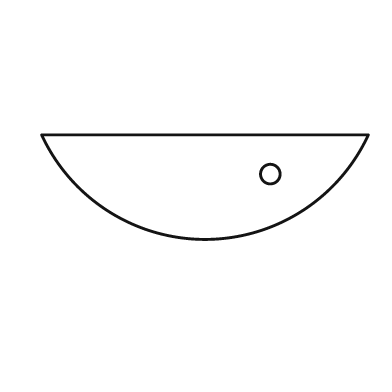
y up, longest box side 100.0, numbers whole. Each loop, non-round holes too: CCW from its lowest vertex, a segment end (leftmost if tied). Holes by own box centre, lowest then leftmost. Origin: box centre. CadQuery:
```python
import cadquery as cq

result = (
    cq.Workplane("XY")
    .moveTo(-50.0, 16.0)
    .threePointArc((0.0, -16.0), (50.0, 16.0))
    .close()
    .moveTo(20.0, 4.0)
    .circle(3.0)
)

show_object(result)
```